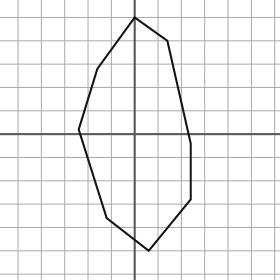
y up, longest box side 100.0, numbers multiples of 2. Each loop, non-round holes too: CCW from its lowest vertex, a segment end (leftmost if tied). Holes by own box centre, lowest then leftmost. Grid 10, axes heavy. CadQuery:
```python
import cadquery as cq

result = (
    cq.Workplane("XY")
    .moveTo(6.0, -50.0)
    .lineTo(24.0, -28.0)
    .lineTo(24.0, -4.0)
    .lineTo(14.0, 40.0)
    .lineTo(0.0, 50.0)
    .lineTo(-16.0, 28.0)
    .lineTo(-24.0, 2.0)
    .lineTo(-12.0, -36.0)
    .close()
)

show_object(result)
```